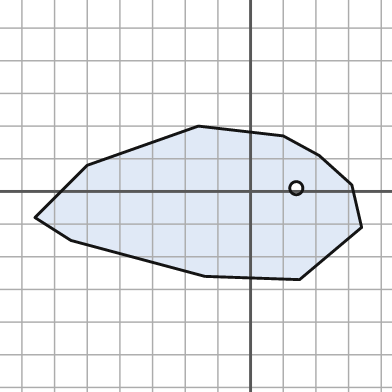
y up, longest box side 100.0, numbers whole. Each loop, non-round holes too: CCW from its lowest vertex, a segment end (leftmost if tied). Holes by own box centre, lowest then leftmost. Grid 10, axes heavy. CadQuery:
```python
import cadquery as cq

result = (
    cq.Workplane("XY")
    .moveTo(15.0, -27.0)
    .lineTo(34.0, -11.0)
    .lineTo(31.0, 2.0)
    .lineTo(21.0, 11.0)
    .lineTo(10.0, 17.0)
    .lineTo(-16.0, 20.0)
    .lineTo(-50.0, 8.0)
    .lineTo(-66.0, -8.0)
    .lineTo(-55.0, -15.0)
    .lineTo(-14.0, -26.0)
    .close()
    .moveTo(14.0, 1.0)
    .circle(2.0)
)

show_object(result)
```